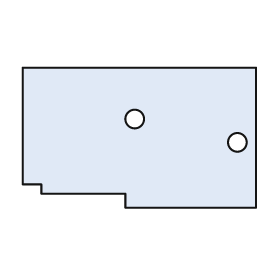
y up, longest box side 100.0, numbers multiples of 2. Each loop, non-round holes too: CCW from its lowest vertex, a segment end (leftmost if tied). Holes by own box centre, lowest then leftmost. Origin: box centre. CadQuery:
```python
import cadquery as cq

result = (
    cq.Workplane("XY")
    .moveTo(-6.0, -30.0)
    .lineTo(50.0, -30.0)
    .lineTo(50.0, 30.0)
    .lineTo(-50.0, 30.0)
    .lineTo(-50.0, -20.0)
    .lineTo(-42.0, -20.0)
    .lineTo(-42.0, -24.0)
    .lineTo(-6.0, -24.0)
    .close()
    .moveTo(42.0, -2.0)
    .circle(4.0)
    .moveTo(-2.0, 8.0)
    .circle(4.0)
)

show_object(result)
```